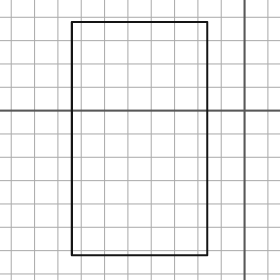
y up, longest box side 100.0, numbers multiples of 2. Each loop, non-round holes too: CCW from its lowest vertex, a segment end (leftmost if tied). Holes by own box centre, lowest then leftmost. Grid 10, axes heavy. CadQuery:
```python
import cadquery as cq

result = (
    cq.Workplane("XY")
    .moveTo(-74.0, -62.0)
    .lineTo(-16.0, -62.0)
    .lineTo(-16.0, 38.0)
    .lineTo(-74.0, 38.0)
    .close()
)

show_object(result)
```